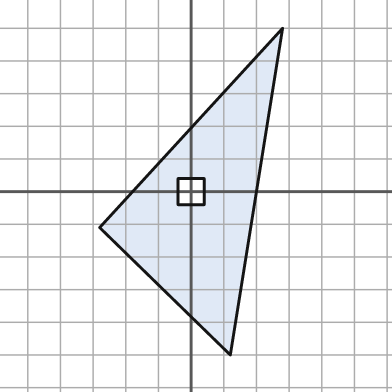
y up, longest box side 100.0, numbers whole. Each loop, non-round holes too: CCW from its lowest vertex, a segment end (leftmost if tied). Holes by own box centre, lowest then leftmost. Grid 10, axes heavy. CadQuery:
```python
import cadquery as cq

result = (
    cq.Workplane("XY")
    .moveTo(12.0, -50.0)
    .lineTo(28.0, 50.0)
    .lineTo(-28.0, -11.0)
    .close()
    .moveTo(-4.0, -4.0)
    .lineTo(4.0, -4.0)
    .lineTo(4.0, 4.0)
    .lineTo(-4.0, 4.0)
    .close()
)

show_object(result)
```